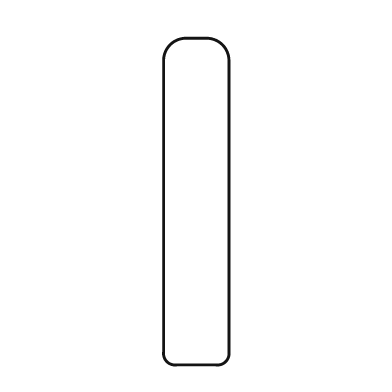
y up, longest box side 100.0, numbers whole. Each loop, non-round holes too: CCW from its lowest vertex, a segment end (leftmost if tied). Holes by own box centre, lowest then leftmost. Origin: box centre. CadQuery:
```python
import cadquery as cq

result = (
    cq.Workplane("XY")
    .moveTo(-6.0, -50.0)
    .lineTo(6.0, -50.0)
    .threePointArc((9.0, -49.0), (10.0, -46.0))
    .lineTo(10.0, 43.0)
    .threePointArc((8.0, 48.0), (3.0, 50.0))
    .lineTo(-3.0, 50.0)
    .threePointArc((-8.0, 48.0), (-10.0, 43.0))
    .lineTo(-10.0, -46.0)
    .threePointArc((-9.0, -49.0), (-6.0, -50.0))
    .close()
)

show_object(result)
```